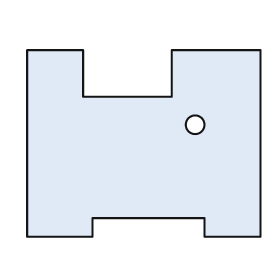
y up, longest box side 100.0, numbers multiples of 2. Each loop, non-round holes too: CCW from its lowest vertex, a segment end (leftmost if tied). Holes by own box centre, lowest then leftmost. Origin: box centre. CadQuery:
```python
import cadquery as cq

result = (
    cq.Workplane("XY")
    .moveTo(-50.0, -40.0)
    .lineTo(-22.0, -40.0)
    .lineTo(-22.0, -32.0)
    .lineTo(26.0, -32.0)
    .lineTo(26.0, -40.0)
    .lineTo(50.0, -40.0)
    .lineTo(50.0, 40.0)
    .lineTo(12.0, 40.0)
    .lineTo(12.0, 20.0)
    .lineTo(-26.0, 20.0)
    .lineTo(-26.0, 40.0)
    .lineTo(-50.0, 40.0)
    .close()
    .moveTo(22.0, 8.0)
    .circle(4.0)
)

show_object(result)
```